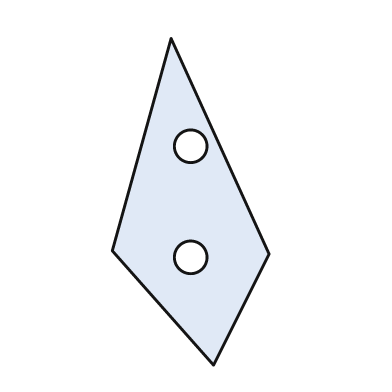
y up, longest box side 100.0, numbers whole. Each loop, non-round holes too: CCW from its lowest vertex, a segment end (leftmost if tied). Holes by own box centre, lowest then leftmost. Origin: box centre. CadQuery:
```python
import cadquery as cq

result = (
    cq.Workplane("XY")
    .moveTo(7.0, -50.0)
    .lineTo(24.0, -16.0)
    .lineTo(-6.0, 50.0)
    .lineTo(-24.0, -15.0)
    .close()
    .moveTo(0.0, -17.0)
    .circle(5.0)
    .moveTo(0.0, 17.0)
    .circle(5.0)
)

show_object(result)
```